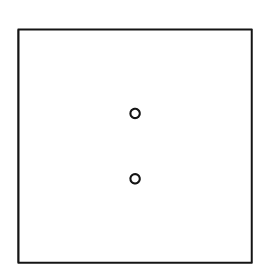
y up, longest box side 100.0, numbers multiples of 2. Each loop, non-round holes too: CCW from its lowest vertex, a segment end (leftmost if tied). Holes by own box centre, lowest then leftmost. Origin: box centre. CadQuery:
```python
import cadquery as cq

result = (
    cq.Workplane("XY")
    .moveTo(-50.0, -50.0)
    .lineTo(50.0, -50.0)
    .lineTo(50.0, 50.0)
    .lineTo(-50.0, 50.0)
    .close()
    .moveTo(0.0, -14.0)
    .circle(2.0)
    .moveTo(0.0, 14.0)
    .circle(2.0)
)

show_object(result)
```